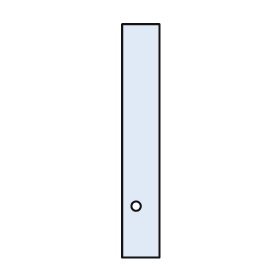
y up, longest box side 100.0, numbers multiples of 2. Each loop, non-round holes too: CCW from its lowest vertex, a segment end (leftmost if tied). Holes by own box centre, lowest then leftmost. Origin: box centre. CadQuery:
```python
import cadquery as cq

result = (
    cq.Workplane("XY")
    .moveTo(-8.0, -50.0)
    .lineTo(8.0, -50.0)
    .lineTo(8.0, 50.0)
    .lineTo(-8.0, 50.0)
    .close()
    .moveTo(-2.0, -28.0)
    .circle(2.0)
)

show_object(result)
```